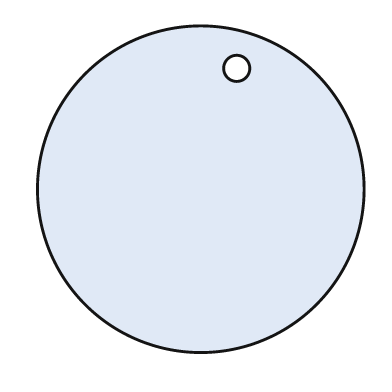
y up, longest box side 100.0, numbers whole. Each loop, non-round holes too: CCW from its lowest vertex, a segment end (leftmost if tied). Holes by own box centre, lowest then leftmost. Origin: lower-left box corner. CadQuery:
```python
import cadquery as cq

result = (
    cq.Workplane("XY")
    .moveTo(50.0, 50.0)
    .circle(50.0)
    .moveTo(61.0, 87.0)
    .circle(4.0)
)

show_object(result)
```